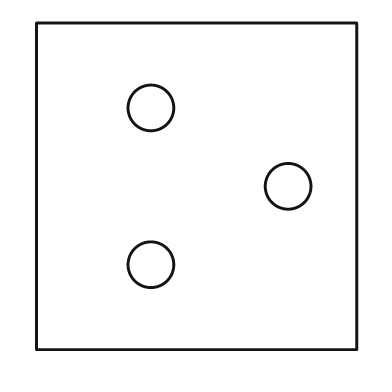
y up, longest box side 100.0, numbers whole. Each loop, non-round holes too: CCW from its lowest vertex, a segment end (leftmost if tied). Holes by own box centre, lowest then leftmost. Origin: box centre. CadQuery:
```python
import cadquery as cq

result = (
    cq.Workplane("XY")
    .moveTo(-49.0, -50.0)
    .lineTo(49.0, -50.0)
    .lineTo(49.0, 50.0)
    .lineTo(-49.0, 50.0)
    .close()
    .moveTo(-14.0, -24.0)
    .circle(7.0)
    .moveTo(28.0, 0.0)
    .circle(7.0)
    .moveTo(-14.0, 24.0)
    .circle(7.0)
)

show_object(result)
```